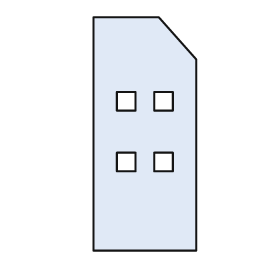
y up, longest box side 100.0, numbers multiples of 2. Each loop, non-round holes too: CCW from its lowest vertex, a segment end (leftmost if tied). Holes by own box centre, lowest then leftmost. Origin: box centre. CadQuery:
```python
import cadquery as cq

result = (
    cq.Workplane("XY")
    .moveTo(-22.0, -50.0)
    .lineTo(22.0, -50.0)
    .lineTo(22.0, 32.0)
    .lineTo(6.0, 50.0)
    .lineTo(-22.0, 50.0)
    .close()
    .moveTo(-12.0, -16.0)
    .lineTo(-4.0, -16.0)
    .lineTo(-4.0, -8.0)
    .lineTo(-12.0, -8.0)
    .close()
    .moveTo(4.0, -16.0)
    .lineTo(12.0, -16.0)
    .lineTo(12.0, -8.0)
    .lineTo(4.0, -8.0)
    .close()
    .moveTo(-12.0, 10.0)
    .lineTo(-4.0, 10.0)
    .lineTo(-4.0, 18.0)
    .lineTo(-12.0, 18.0)
    .close()
    .moveTo(4.0, 10.0)
    .lineTo(12.0, 10.0)
    .lineTo(12.0, 18.0)
    .lineTo(4.0, 18.0)
    .close()
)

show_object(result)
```